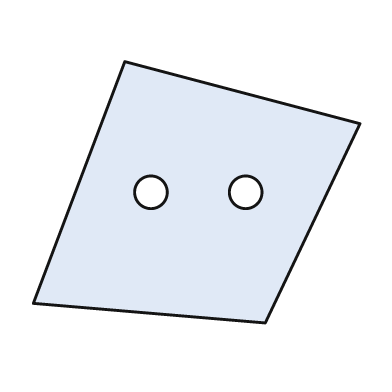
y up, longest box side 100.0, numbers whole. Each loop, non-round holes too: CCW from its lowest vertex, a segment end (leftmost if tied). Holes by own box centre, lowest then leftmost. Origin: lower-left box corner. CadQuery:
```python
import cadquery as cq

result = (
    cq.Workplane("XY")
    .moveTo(71.0, 0.0)
    .lineTo(100.0, 61.0)
    .lineTo(28.0, 80.0)
    .lineTo(0.0, 6.0)
    .close()
    .moveTo(36.0, 40.0)
    .circle(5.0)
    .moveTo(65.0, 40.0)
    .circle(5.0)
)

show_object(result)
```